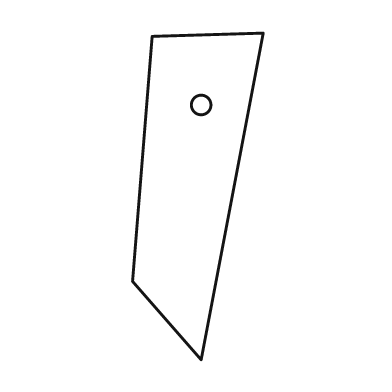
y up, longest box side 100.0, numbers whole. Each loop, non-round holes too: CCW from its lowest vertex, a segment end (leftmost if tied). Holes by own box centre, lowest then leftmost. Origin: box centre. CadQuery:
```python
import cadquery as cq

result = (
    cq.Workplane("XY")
    .moveTo(1.0, -50.0)
    .lineTo(20.0, 50.0)
    .lineTo(-14.0, 49.0)
    .lineTo(-20.0, -26.0)
    .close()
    .moveTo(1.0, 28.0)
    .circle(3.0)
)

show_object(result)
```